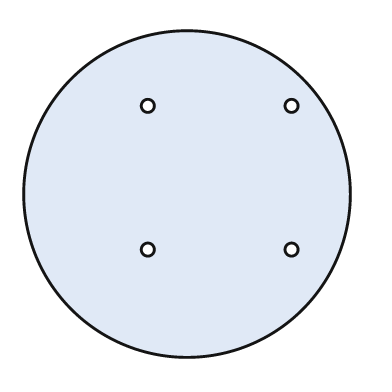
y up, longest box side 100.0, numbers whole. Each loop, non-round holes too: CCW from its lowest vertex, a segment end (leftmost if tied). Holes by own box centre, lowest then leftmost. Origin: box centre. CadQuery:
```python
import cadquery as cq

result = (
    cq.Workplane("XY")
    .moveTo(0.0, 0.0)
    .circle(50.0)
    .moveTo(-12.0, -17.0)
    .circle(2.0)
    .moveTo(32.0, -17.0)
    .circle(2.0)
    .moveTo(-12.0, 27.0)
    .circle(2.0)
    .moveTo(32.0, 27.0)
    .circle(2.0)
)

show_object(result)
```